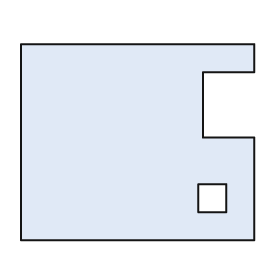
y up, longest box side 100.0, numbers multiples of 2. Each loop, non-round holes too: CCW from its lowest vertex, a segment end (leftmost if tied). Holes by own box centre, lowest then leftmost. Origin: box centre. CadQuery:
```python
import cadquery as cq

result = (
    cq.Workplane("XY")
    .moveTo(-50.0, -42.0)
    .lineTo(50.0, -42.0)
    .lineTo(50.0, 2.0)
    .lineTo(28.0, 2.0)
    .lineTo(28.0, 30.0)
    .lineTo(50.0, 30.0)
    .lineTo(50.0, 42.0)
    .lineTo(-50.0, 42.0)
    .close()
    .moveTo(26.0, -30.0)
    .lineTo(38.0, -30.0)
    .lineTo(38.0, -18.0)
    .lineTo(26.0, -18.0)
    .close()
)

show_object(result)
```